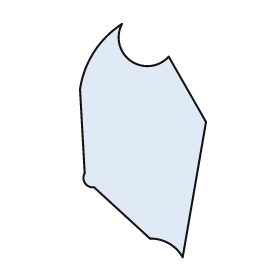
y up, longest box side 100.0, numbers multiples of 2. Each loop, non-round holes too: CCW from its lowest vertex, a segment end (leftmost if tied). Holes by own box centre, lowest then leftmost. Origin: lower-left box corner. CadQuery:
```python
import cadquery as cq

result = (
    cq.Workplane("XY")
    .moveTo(44.0, 0.0)
    .lineTo(54.0, 58.0)
    .lineTo(38.0, 86.0)
    .threePointArc((22.0, 84.0), (18.0, 100.0))
    .threePointArc((6.0, 88.0), (0.0, 72.0))
    .lineTo(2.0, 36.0)
    .threePointArc((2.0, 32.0), (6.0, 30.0))
    .lineTo(30.0, 8.0)
    .threePointArc((38.0, 6.0), (44.0, 0.0))
    .close()
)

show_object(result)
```